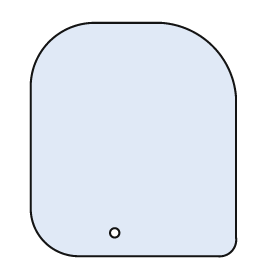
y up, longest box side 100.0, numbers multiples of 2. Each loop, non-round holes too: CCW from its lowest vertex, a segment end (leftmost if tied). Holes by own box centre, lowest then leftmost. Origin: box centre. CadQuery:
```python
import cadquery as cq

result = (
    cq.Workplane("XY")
    .moveTo(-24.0, -50.0)
    .lineTo(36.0, -50.0)
    .threePointArc((42.0, -48.0), (44.0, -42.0))
    .lineTo(44.0, 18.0)
    .threePointArc((34.0, 40.0), (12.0, 50.0))
    .lineTo(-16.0, 50.0)
    .threePointArc((-36.0, 42.0), (-44.0, 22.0))
    .lineTo(-44.0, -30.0)
    .threePointArc((-38.0, -44.0), (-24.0, -50.0))
    .close()
    .moveTo(-8.0, -40.0)
    .circle(2.0)
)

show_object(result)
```